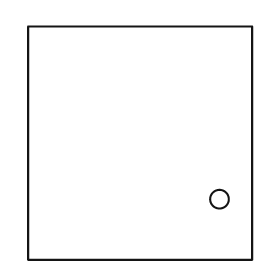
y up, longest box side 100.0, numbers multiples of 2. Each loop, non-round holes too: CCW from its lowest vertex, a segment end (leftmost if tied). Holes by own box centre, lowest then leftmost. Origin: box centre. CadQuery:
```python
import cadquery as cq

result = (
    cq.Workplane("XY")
    .moveTo(-48.0, -50.0)
    .lineTo(48.0, -50.0)
    .lineTo(48.0, 50.0)
    .lineTo(-48.0, 50.0)
    .close()
    .moveTo(34.0, -24.0)
    .circle(4.0)
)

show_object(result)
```